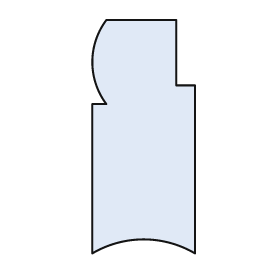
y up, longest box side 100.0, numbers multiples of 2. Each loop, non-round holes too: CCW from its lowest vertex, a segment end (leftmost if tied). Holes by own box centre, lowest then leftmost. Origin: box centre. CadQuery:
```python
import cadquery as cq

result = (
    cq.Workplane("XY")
    .moveTo(-22.0, -50.0)
    .threePointArc((0.0, -44.0), (22.0, -50.0))
    .lineTo(22.0, 22.0)
    .lineTo(14.0, 22.0)
    .lineTo(14.0, 50.0)
    .lineTo(-16.0, 50.0)
    .threePointArc((-22.0, 32.0), (-16.0, 14.0))
    .lineTo(-22.0, 14.0)
    .close()
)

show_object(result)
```